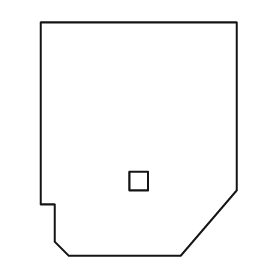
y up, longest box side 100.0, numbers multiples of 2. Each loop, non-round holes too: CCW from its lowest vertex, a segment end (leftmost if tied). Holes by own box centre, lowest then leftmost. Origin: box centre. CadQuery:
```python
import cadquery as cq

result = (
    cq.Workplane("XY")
    .moveTo(-30.0, -50.0)
    .lineTo(18.0, -50.0)
    .lineTo(42.0, -22.0)
    .lineTo(42.0, 50.0)
    .lineTo(-42.0, 50.0)
    .lineTo(-42.0, -28.0)
    .lineTo(-36.0, -28.0)
    .lineTo(-36.0, -44.0)
    .close()
    .moveTo(-4.0, -22.0)
    .lineTo(4.0, -22.0)
    .lineTo(4.0, -14.0)
    .lineTo(-4.0, -14.0)
    .close()
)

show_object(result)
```